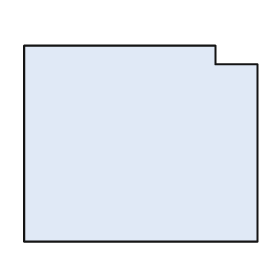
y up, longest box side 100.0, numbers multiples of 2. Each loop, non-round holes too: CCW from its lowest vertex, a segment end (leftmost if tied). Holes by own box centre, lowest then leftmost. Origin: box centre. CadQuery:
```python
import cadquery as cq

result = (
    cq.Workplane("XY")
    .moveTo(-50.0, -42.0)
    .lineTo(50.0, -42.0)
    .lineTo(50.0, 34.0)
    .lineTo(32.0, 34.0)
    .lineTo(32.0, 42.0)
    .lineTo(-50.0, 42.0)
    .close()
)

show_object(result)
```